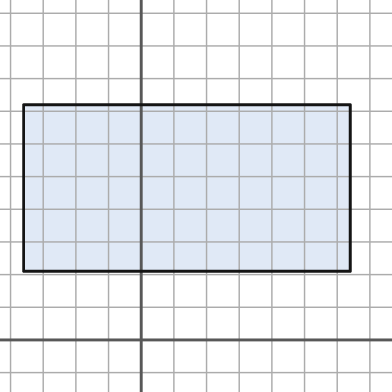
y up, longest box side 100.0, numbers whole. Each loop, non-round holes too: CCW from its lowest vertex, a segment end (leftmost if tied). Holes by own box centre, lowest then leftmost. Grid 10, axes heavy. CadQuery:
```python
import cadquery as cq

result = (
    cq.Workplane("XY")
    .moveTo(-36.0, 21.0)
    .lineTo(64.0, 21.0)
    .lineTo(64.0, 72.0)
    .lineTo(-36.0, 72.0)
    .close()
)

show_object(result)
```